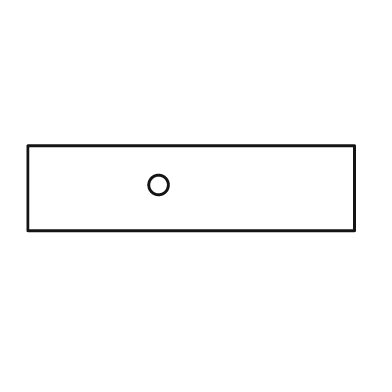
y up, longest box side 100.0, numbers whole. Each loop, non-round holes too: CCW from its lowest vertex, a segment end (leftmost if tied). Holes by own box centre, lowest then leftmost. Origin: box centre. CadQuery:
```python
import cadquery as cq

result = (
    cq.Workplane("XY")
    .moveTo(-50.0, -13.0)
    .lineTo(50.0, -13.0)
    .lineTo(50.0, 13.0)
    .lineTo(-50.0, 13.0)
    .close()
    .moveTo(-10.0, 1.0)
    .circle(3.0)
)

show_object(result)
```